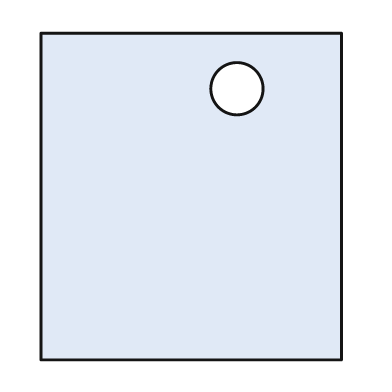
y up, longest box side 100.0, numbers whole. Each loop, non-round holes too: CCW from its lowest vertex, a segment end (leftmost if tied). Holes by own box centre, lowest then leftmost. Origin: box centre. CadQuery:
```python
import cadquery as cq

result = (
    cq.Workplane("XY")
    .moveTo(-46.0, -50.0)
    .lineTo(46.0, -50.0)
    .lineTo(46.0, 50.0)
    .lineTo(-46.0, 50.0)
    .close()
    .moveTo(14.0, 33.0)
    .circle(8.0)
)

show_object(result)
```